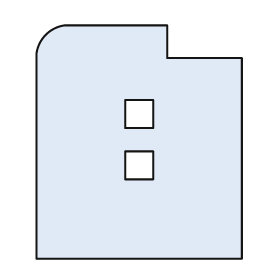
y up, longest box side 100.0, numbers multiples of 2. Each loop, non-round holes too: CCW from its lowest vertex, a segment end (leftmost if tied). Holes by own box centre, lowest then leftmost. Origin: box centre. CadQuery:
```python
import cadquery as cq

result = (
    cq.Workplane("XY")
    .moveTo(-44.0, -50.0)
    .lineTo(44.0, -50.0)
    .lineTo(44.0, 36.0)
    .lineTo(12.0, 36.0)
    .lineTo(12.0, 50.0)
    .lineTo(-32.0, 50.0)
    .threePointArc((-40.0, 46.0), (-44.0, 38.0))
    .close()
    .moveTo(-6.0, -16.0)
    .lineTo(6.0, -16.0)
    .lineTo(6.0, -4.0)
    .lineTo(-6.0, -4.0)
    .close()
    .moveTo(-6.0, 6.0)
    .lineTo(6.0, 6.0)
    .lineTo(6.0, 18.0)
    .lineTo(-6.0, 18.0)
    .close()
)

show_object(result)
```